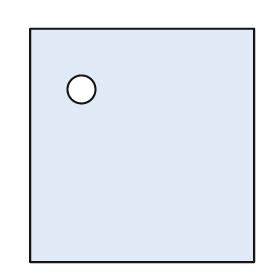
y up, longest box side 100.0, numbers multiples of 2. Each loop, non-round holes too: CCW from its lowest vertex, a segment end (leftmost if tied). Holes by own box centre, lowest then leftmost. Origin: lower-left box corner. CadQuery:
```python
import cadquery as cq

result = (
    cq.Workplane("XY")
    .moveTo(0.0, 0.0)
    .lineTo(96.0, 0.0)
    .lineTo(96.0, 100.0)
    .lineTo(0.0, 100.0)
    .close()
    .moveTo(22.0, 74.0)
    .circle(6.0)
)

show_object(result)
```